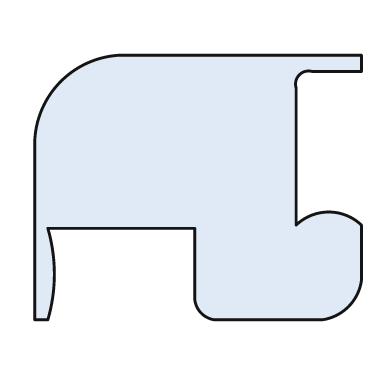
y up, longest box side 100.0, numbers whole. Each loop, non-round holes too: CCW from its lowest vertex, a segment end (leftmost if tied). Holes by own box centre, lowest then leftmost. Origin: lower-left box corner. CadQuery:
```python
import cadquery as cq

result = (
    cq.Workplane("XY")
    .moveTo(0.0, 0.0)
    .lineTo(4.0, 0.0)
    .threePointArc((6.0, 14.0), (4.0, 28.0))
    .lineTo(49.0, 28.0)
    .lineTo(49.0, 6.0)
    .threePointArc((51.0, 2.0), (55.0, 0.0))
    .lineTo(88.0, 0.0)
    .threePointArc((96.0, 4.0), (100.0, 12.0))
    .lineTo(100.0, 29.0)
    .threePointArc((90.0, 33.0), (80.0, 29.0))
    .lineTo(80.0, 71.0)
    .threePointArc((81.0, 75.0), (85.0, 76.0))
    .lineTo(100.0, 76.0)
    .lineTo(100.0, 81.0)
    .lineTo(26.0, 81.0)
    .threePointArc((8.0, 73.0), (0.0, 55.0))
    .close()
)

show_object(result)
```